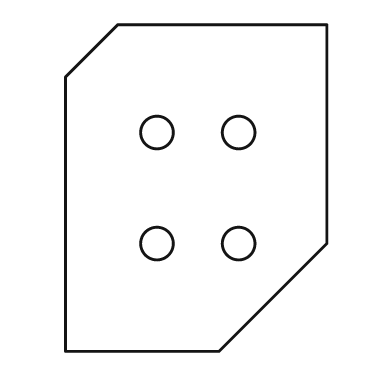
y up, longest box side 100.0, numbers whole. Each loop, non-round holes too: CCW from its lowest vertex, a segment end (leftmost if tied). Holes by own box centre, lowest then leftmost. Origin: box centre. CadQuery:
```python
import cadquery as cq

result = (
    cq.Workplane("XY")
    .moveTo(-40.0, -50.0)
    .lineTo(7.0, -50.0)
    .lineTo(40.0, -17.0)
    .lineTo(40.0, 50.0)
    .lineTo(-24.0, 50.0)
    .lineTo(-40.0, 34.0)
    .close()
    .moveTo(-12.0, -17.0)
    .circle(5.0)
    .moveTo(13.0, -17.0)
    .circle(5.0)
    .moveTo(-12.0, 17.0)
    .circle(5.0)
    .moveTo(13.0, 17.0)
    .circle(5.0)
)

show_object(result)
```